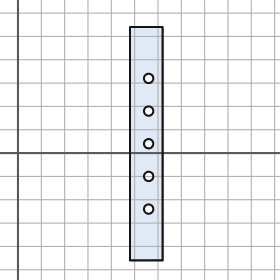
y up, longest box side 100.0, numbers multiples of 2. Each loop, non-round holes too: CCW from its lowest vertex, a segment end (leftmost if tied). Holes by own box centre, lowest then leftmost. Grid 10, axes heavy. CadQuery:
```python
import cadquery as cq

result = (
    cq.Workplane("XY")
    .moveTo(48.0, -46.0)
    .lineTo(62.0, -46.0)
    .lineTo(62.0, 54.0)
    .lineTo(48.0, 54.0)
    .close()
    .moveTo(56.0, -24.0)
    .circle(2.0)
    .moveTo(56.0, -10.0)
    .circle(2.0)
    .moveTo(56.0, 4.0)
    .circle(2.0)
    .moveTo(56.0, 18.0)
    .circle(2.0)
    .moveTo(56.0, 32.0)
    .circle(2.0)
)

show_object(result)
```